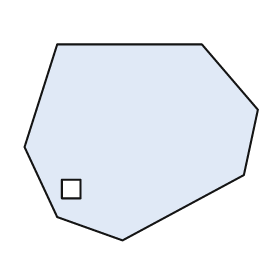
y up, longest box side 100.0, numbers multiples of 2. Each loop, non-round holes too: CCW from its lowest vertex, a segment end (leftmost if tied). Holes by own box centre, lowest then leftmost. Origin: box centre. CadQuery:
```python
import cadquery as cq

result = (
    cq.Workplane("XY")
    .moveTo(-8.0, -42.0)
    .lineTo(44.0, -14.0)
    .lineTo(50.0, 14.0)
    .lineTo(26.0, 42.0)
    .lineTo(-36.0, 42.0)
    .lineTo(-50.0, -2.0)
    .lineTo(-36.0, -32.0)
    .close()
    .moveTo(-34.0, -24.0)
    .lineTo(-26.0, -24.0)
    .lineTo(-26.0, -16.0)
    .lineTo(-34.0, -16.0)
    .close()
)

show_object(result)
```